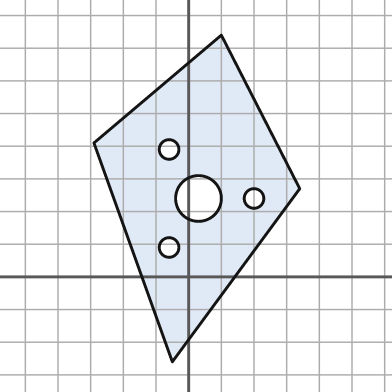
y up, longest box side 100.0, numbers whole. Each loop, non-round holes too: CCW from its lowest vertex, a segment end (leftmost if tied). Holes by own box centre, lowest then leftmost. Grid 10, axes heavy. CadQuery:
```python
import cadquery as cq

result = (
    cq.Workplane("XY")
    .moveTo(-5.0, -26.0)
    .lineTo(34.0, 27.0)
    .lineTo(10.0, 74.0)
    .lineTo(-29.0, 41.0)
    .close()
    .moveTo(-6.0, 9.0)
    .circle(3.0)
    .moveTo(3.0, 24.0)
    .circle(7.0)
    .moveTo(20.0, 24.0)
    .circle(3.0)
    .moveTo(-6.0, 39.0)
    .circle(3.0)
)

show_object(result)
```